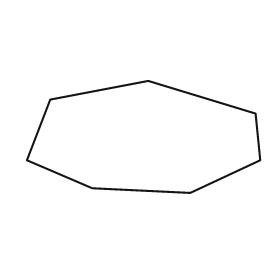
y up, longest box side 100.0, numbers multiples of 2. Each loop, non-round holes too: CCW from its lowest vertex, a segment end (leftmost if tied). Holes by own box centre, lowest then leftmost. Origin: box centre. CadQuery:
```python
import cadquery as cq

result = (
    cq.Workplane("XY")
    .moveTo(20.0, -24.0)
    .lineTo(50.0, -10.0)
    .lineTo(48.0, 10.0)
    .lineTo(2.0, 24.0)
    .lineTo(-40.0, 16.0)
    .lineTo(-50.0, -10.0)
    .lineTo(-22.0, -22.0)
    .close()
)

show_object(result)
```